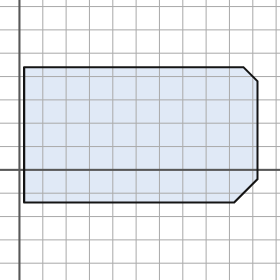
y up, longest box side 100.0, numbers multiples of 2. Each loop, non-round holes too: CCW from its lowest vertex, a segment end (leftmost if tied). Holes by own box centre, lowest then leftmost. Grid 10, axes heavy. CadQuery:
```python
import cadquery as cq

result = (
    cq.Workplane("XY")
    .moveTo(2.0, -14.0)
    .lineTo(92.0, -14.0)
    .lineTo(102.0, -4.0)
    .lineTo(102.0, 38.0)
    .lineTo(96.0, 44.0)
    .lineTo(2.0, 44.0)
    .close()
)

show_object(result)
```